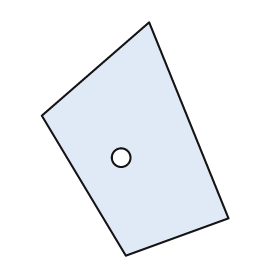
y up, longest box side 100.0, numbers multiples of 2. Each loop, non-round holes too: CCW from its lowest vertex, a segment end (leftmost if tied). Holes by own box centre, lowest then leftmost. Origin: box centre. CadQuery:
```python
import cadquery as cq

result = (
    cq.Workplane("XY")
    .moveTo(-4.0, -50.0)
    .lineTo(40.0, -34.0)
    .lineTo(6.0, 50.0)
    .lineTo(-40.0, 10.0)
    .close()
    .moveTo(-6.0, -8.0)
    .circle(4.0)
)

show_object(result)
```